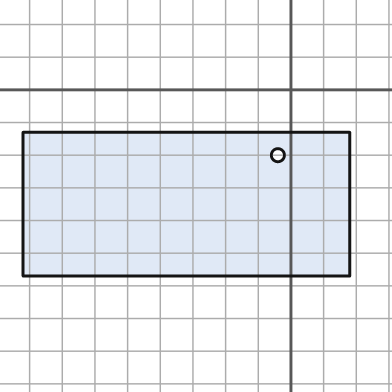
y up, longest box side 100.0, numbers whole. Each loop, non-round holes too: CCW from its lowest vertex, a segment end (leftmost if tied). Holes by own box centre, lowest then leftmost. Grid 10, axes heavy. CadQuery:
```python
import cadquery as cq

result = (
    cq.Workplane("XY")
    .moveTo(-82.0, -57.0)
    .lineTo(18.0, -57.0)
    .lineTo(18.0, -13.0)
    .lineTo(-82.0, -13.0)
    .close()
    .moveTo(-4.0, -20.0)
    .circle(2.0)
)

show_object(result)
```